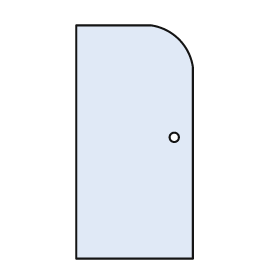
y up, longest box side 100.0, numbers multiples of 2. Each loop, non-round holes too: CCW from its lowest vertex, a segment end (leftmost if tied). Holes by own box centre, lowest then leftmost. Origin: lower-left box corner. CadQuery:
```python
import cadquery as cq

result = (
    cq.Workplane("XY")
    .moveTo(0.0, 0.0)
    .lineTo(50.0, 0.0)
    .lineTo(50.0, 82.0)
    .threePointArc((44.0, 94.0), (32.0, 100.0))
    .lineTo(0.0, 100.0)
    .close()
    .moveTo(42.0, 52.0)
    .circle(2.0)
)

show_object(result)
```